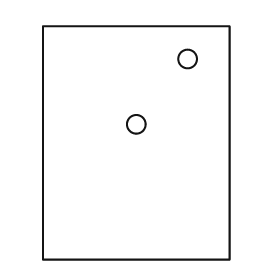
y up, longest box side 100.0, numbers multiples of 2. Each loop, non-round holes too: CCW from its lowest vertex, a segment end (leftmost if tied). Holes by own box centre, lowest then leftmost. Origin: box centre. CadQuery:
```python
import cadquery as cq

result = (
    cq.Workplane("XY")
    .moveTo(-40.0, -50.0)
    .lineTo(40.0, -50.0)
    .lineTo(40.0, 50.0)
    .lineTo(-40.0, 50.0)
    .close()
    .moveTo(0.0, 8.0)
    .circle(4.0)
    .moveTo(22.0, 36.0)
    .circle(4.0)
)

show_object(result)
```